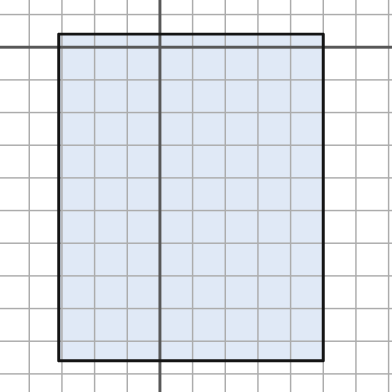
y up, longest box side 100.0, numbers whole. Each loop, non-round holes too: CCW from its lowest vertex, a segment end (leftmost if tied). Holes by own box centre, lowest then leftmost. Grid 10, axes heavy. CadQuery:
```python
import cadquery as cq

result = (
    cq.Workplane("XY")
    .moveTo(-31.0, -96.0)
    .lineTo(50.0, -96.0)
    .lineTo(50.0, 4.0)
    .lineTo(-31.0, 4.0)
    .close()
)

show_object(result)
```